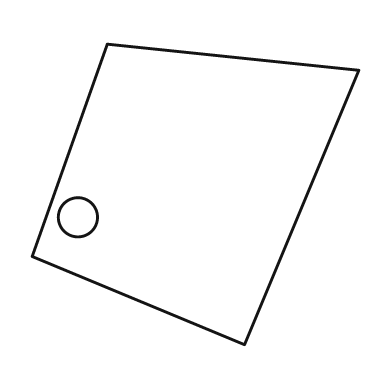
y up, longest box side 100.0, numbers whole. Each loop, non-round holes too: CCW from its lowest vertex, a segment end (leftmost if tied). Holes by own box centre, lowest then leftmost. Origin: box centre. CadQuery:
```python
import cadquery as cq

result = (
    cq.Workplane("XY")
    .moveTo(15.0, -46.0)
    .lineTo(50.0, 38.0)
    .lineTo(-27.0, 46.0)
    .lineTo(-50.0, -19.0)
    .close()
    .moveTo(-36.0, -7.0)
    .circle(6.0)
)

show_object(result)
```